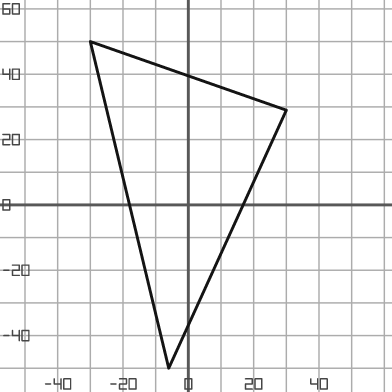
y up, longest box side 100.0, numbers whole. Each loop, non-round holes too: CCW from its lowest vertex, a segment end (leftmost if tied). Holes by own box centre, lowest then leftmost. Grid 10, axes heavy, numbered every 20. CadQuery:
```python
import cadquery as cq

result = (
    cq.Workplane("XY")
    .moveTo(-6.0, -50.0)
    .lineTo(30.0, 29.0)
    .lineTo(-30.0, 50.0)
    .close()
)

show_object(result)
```